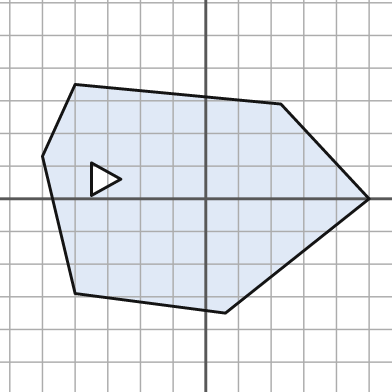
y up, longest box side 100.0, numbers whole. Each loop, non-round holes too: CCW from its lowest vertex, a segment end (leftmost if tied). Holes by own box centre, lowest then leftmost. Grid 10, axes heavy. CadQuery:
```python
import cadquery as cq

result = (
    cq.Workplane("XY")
    .moveTo(6.0, -35.0)
    .lineTo(50.0, 0.0)
    .lineTo(23.0, 29.0)
    .lineTo(-40.0, 35.0)
    .lineTo(-50.0, 13.0)
    .lineTo(-40.0, -29.0)
    .close()
    .moveTo(-35.0, 1.0)
    .lineTo(-26.0, 6.0)
    .lineTo(-35.0, 11.0)
    .close()
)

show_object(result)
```